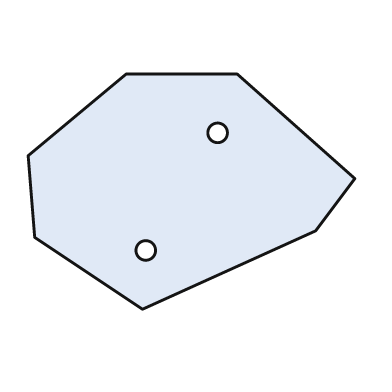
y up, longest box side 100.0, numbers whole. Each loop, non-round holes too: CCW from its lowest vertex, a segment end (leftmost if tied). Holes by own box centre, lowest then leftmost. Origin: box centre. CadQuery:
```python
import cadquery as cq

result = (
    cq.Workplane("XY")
    .moveTo(-15.0, -36.0)
    .lineTo(38.0, -12.0)
    .lineTo(50.0, 4.0)
    .lineTo(14.0, 36.0)
    .lineTo(-20.0, 36.0)
    .lineTo(-50.0, 11.0)
    .lineTo(-48.0, -14.0)
    .close()
    .moveTo(-14.0, -18.0)
    .circle(3.0)
    .moveTo(8.0, 18.0)
    .circle(3.0)
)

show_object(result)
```